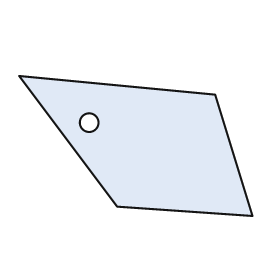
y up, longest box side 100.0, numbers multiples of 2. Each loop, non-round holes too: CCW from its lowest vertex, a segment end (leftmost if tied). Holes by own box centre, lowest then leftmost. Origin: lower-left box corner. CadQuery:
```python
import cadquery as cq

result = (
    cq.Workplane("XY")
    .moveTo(100.0, 0.0)
    .lineTo(84.0, 52.0)
    .lineTo(0.0, 60.0)
    .lineTo(42.0, 4.0)
    .close()
    .moveTo(30.0, 40.0)
    .circle(4.0)
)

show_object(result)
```